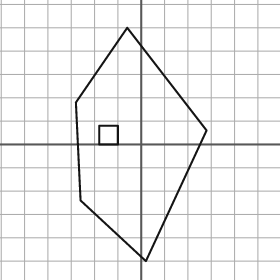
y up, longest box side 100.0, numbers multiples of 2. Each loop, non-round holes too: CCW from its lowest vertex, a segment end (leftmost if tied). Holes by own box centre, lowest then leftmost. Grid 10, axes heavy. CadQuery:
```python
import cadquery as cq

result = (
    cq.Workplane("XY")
    .moveTo(2.0, -50.0)
    .lineTo(28.0, 6.0)
    .lineTo(-6.0, 50.0)
    .lineTo(-28.0, 18.0)
    .lineTo(-26.0, -24.0)
    .close()
    .moveTo(-18.0, 0.0)
    .lineTo(-10.0, 0.0)
    .lineTo(-10.0, 8.0)
    .lineTo(-18.0, 8.0)
    .close()
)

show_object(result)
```